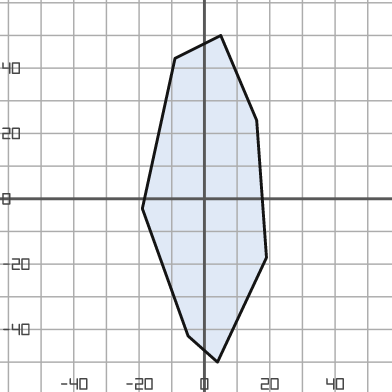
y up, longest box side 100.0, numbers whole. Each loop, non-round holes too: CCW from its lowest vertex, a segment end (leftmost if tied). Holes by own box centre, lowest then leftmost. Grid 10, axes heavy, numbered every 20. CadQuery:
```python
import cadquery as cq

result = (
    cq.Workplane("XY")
    .moveTo(4.0, -50.0)
    .lineTo(19.0, -18.0)
    .lineTo(16.0, 24.0)
    .lineTo(5.0, 50.0)
    .lineTo(-9.0, 43.0)
    .lineTo(-19.0, -3.0)
    .lineTo(-5.0, -42.0)
    .close()
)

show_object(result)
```